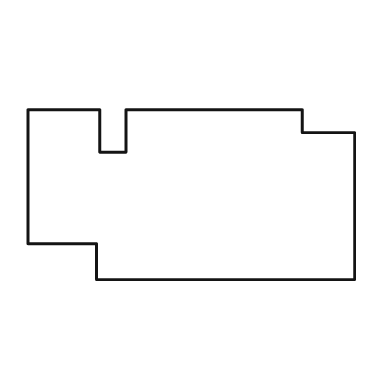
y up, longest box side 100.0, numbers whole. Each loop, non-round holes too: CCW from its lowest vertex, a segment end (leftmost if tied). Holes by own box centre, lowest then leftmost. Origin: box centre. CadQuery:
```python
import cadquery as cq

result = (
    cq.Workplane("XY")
    .moveTo(-29.0, -26.0)
    .lineTo(50.0, -26.0)
    .lineTo(50.0, 19.0)
    .lineTo(34.0, 19.0)
    .lineTo(34.0, 26.0)
    .lineTo(-20.0, 26.0)
    .lineTo(-20.0, 13.0)
    .lineTo(-28.0, 13.0)
    .lineTo(-28.0, 26.0)
    .lineTo(-50.0, 26.0)
    .lineTo(-50.0, -15.0)
    .lineTo(-29.0, -15.0)
    .close()
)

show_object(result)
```